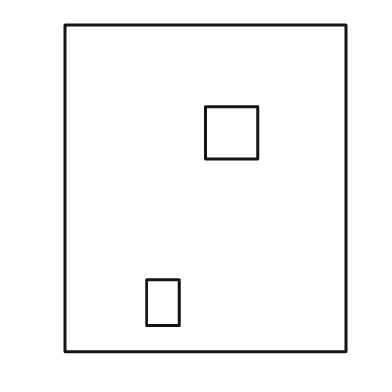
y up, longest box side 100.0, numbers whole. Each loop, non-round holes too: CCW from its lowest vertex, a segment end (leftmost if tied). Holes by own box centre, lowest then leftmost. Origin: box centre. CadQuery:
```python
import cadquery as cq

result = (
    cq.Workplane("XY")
    .moveTo(-43.0, -50.0)
    .lineTo(43.0, -50.0)
    .lineTo(43.0, 50.0)
    .lineTo(-43.0, 50.0)
    .close()
    .moveTo(-18.0, -42.0)
    .lineTo(-8.0, -42.0)
    .lineTo(-8.0, -28.0)
    .lineTo(-18.0, -28.0)
    .close()
    .moveTo(0.0, 9.0)
    .lineTo(16.0, 9.0)
    .lineTo(16.0, 25.0)
    .lineTo(0.0, 25.0)
    .close()
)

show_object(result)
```